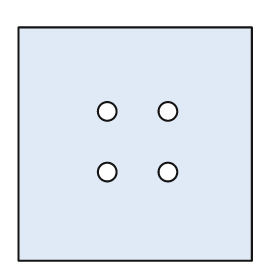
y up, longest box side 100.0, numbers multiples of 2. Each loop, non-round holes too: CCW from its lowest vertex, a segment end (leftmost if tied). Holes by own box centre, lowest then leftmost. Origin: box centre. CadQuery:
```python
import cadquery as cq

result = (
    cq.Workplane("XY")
    .moveTo(-50.0, -50.0)
    .lineTo(50.0, -50.0)
    .lineTo(50.0, 50.0)
    .lineTo(-50.0, 50.0)
    .close()
    .moveTo(-12.0, -12.0)
    .circle(4.0)
    .moveTo(14.0, -12.0)
    .circle(4.0)
    .moveTo(-12.0, 14.0)
    .circle(4.0)
    .moveTo(14.0, 14.0)
    .circle(4.0)
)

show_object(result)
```